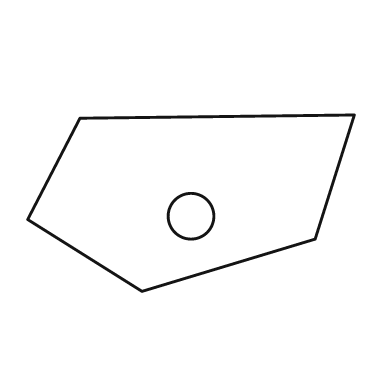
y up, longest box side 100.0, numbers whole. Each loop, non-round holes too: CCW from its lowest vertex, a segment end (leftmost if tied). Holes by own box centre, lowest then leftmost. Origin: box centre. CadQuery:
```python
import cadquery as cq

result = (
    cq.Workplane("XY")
    .moveTo(-15.0, -27.0)
    .lineTo(38.0, -11.0)
    .lineTo(50.0, 27.0)
    .lineTo(-34.0, 26.0)
    .lineTo(-50.0, -5.0)
    .close()
    .moveTo(0.0, -4.0)
    .circle(7.0)
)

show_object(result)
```